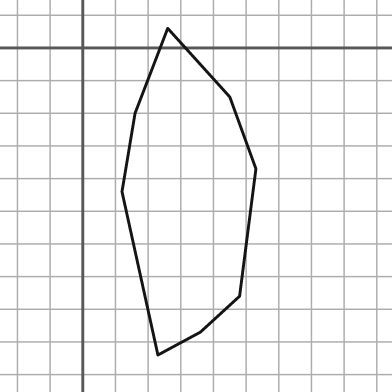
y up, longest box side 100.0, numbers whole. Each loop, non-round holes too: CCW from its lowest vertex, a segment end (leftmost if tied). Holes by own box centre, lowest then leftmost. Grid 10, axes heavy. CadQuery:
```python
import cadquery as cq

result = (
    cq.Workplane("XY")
    .moveTo(23.0, -94.0)
    .lineTo(36.0, -87.0)
    .lineTo(48.0, -76.0)
    .lineTo(53.0, -37.0)
    .lineTo(45.0, -15.0)
    .lineTo(26.0, 6.0)
    .lineTo(16.0, -20.0)
    .lineTo(12.0, -44.0)
    .close()
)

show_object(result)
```